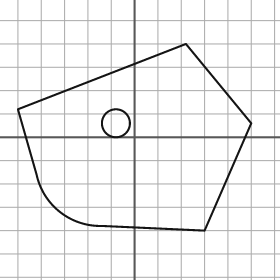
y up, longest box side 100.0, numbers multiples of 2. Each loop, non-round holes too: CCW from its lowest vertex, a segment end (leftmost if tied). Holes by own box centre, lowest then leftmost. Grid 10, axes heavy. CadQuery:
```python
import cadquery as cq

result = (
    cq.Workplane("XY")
    .moveTo(30.0, -40.0)
    .lineTo(50.0, 6.0)
    .lineTo(22.0, 40.0)
    .lineTo(-50.0, 12.0)
    .lineTo(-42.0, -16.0)
    .threePointArc((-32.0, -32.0), (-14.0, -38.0))
    .close()
    .moveTo(-8.0, 6.0)
    .circle(6.0)
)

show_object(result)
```